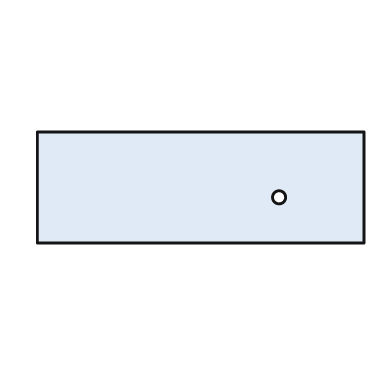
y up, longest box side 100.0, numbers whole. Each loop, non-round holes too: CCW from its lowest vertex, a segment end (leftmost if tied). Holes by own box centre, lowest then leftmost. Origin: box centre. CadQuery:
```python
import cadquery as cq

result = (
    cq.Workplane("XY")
    .moveTo(-50.0, -17.0)
    .lineTo(50.0, -17.0)
    .lineTo(50.0, 17.0)
    .lineTo(-50.0, 17.0)
    .close()
    .moveTo(24.0, -3.0)
    .circle(2.0)
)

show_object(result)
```